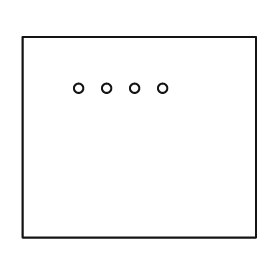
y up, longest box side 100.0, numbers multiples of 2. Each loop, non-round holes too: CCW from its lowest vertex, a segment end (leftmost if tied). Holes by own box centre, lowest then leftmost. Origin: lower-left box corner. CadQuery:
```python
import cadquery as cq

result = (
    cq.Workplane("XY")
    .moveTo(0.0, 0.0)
    .lineTo(100.0, 0.0)
    .lineTo(100.0, 86.0)
    .lineTo(0.0, 86.0)
    .close()
    .moveTo(24.0, 64.0)
    .circle(2.0)
    .moveTo(36.0, 64.0)
    .circle(2.0)
    .moveTo(48.0, 64.0)
    .circle(2.0)
    .moveTo(60.0, 64.0)
    .circle(2.0)
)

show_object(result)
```